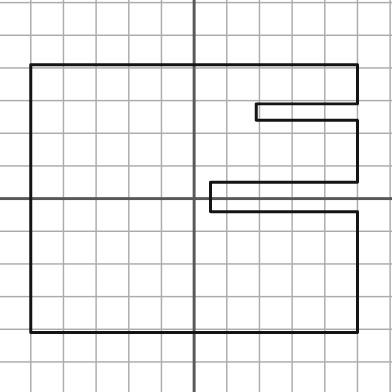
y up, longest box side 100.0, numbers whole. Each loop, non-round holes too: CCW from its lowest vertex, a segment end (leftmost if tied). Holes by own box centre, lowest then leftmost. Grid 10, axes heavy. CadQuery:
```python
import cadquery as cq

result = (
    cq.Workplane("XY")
    .moveTo(-50.0, -41.0)
    .lineTo(50.0, -41.0)
    .lineTo(50.0, -4.0)
    .lineTo(5.0, -4.0)
    .lineTo(5.0, 5.0)
    .lineTo(50.0, 5.0)
    .lineTo(50.0, 24.0)
    .lineTo(19.0, 24.0)
    .lineTo(19.0, 29.0)
    .lineTo(50.0, 29.0)
    .lineTo(50.0, 41.0)
    .lineTo(-50.0, 41.0)
    .close()
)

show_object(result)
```